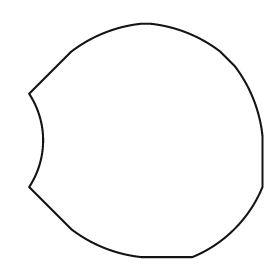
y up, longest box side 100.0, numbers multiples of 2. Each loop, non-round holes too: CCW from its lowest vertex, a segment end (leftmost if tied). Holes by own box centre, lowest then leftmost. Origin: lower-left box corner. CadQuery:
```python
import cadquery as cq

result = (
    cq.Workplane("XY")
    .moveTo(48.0, 0.0)
    .lineTo(70.0, 0.0)
    .threePointArc((88.0, 12.0), (100.0, 30.0))
    .lineTo(100.0, 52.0)
    .threePointArc((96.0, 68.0), (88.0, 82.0))
    .lineTo(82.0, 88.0)
    .threePointArc((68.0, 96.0), (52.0, 100.0))
    .lineTo(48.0, 100.0)
    .threePointArc((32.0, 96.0), (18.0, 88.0))
    .lineTo(0.0, 70.0)
    .threePointArc((6.0, 50.0), (0.0, 30.0))
    .lineTo(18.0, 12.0)
    .threePointArc((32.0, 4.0), (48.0, 0.0))
    .close()
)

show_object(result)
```